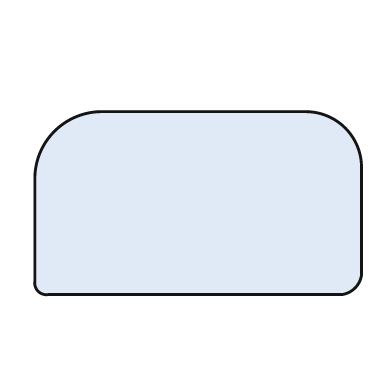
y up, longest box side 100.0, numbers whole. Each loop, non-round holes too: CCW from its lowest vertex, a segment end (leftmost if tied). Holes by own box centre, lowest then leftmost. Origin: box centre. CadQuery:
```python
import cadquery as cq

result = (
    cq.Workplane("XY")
    .moveTo(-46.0, -28.0)
    .lineTo(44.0, -28.0)
    .threePointArc((48.0, -26.0), (50.0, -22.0))
    .lineTo(50.0, 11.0)
    .threePointArc((45.0, 23.0), (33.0, 28.0))
    .lineTo(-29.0, 28.0)
    .threePointArc((-44.0, 22.0), (-50.0, 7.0))
    .lineTo(-50.0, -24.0)
    .threePointArc((-49.0, -27.0), (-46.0, -28.0))
    .close()
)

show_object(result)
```